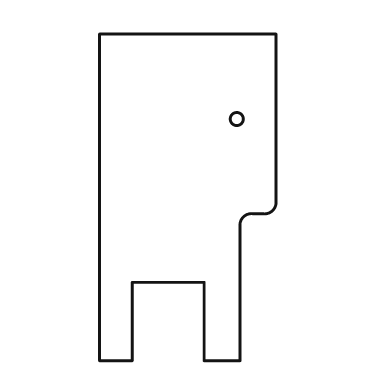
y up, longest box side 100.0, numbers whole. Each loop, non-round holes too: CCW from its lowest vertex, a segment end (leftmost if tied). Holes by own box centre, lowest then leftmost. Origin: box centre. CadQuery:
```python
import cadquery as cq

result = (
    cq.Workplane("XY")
    .moveTo(-27.0, -50.0)
    .lineTo(-17.0, -50.0)
    .lineTo(-17.0, -26.0)
    .lineTo(5.0, -26.0)
    .lineTo(5.0, -50.0)
    .lineTo(16.0, -50.0)
    .lineTo(16.0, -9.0)
    .threePointArc((17.0, -6.0), (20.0, -5.0))
    .lineTo(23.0, -5.0)
    .threePointArc((26.0, -4.0), (27.0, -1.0))
    .lineTo(27.0, 50.0)
    .lineTo(-27.0, 50.0)
    .close()
    .moveTo(15.0, 24.0)
    .circle(2.0)
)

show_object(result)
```